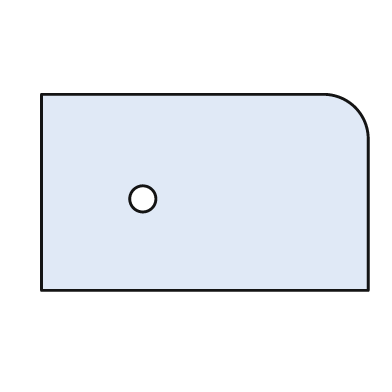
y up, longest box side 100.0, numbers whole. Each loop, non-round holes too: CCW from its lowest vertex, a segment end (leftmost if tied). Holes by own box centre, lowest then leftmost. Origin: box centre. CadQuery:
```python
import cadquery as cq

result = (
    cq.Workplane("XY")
    .moveTo(-50.0, -30.0)
    .lineTo(50.0, -30.0)
    .lineTo(50.0, 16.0)
    .threePointArc((46.0, 26.0), (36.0, 30.0))
    .lineTo(-50.0, 30.0)
    .close()
    .moveTo(-19.0, -2.0)
    .circle(4.0)
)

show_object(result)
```